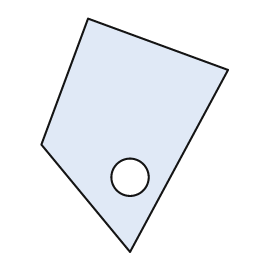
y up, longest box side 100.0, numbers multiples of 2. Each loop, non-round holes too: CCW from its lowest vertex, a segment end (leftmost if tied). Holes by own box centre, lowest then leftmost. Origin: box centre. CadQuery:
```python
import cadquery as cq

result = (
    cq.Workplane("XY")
    .moveTo(-2.0, -50.0)
    .lineTo(40.0, 28.0)
    .lineTo(-20.0, 50.0)
    .lineTo(-40.0, -4.0)
    .close()
    .moveTo(-2.0, -18.0)
    .circle(8.0)
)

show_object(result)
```